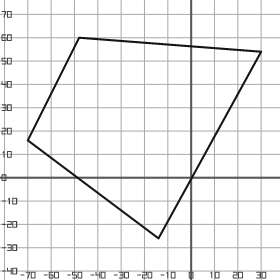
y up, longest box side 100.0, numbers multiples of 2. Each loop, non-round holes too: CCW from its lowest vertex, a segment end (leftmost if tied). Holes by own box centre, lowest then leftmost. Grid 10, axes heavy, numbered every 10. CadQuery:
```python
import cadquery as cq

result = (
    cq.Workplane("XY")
    .moveTo(-14.0, -26.0)
    .lineTo(30.0, 54.0)
    .lineTo(-48.0, 60.0)
    .lineTo(-70.0, 16.0)
    .close()
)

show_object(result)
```